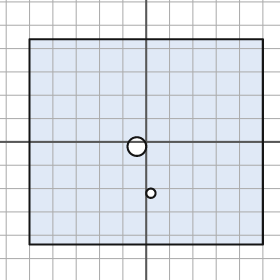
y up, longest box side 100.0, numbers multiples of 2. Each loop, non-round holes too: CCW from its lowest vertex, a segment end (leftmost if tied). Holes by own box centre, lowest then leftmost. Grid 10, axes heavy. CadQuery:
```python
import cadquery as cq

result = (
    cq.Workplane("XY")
    .moveTo(-50.0, -44.0)
    .lineTo(50.0, -44.0)
    .lineTo(50.0, 44.0)
    .lineTo(-50.0, 44.0)
    .close()
    .moveTo(2.0, -22.0)
    .circle(2.0)
    .moveTo(-4.0, -2.0)
    .circle(4.0)
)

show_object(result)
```